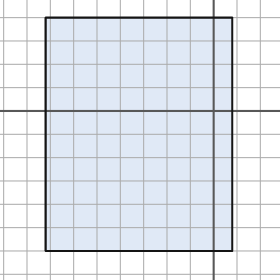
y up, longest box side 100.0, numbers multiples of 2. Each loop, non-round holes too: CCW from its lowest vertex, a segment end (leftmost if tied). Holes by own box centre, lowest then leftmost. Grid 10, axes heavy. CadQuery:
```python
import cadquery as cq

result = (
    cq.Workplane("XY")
    .moveTo(-72.0, -60.0)
    .lineTo(8.0, -60.0)
    .lineTo(8.0, 40.0)
    .lineTo(-72.0, 40.0)
    .close()
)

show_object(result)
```